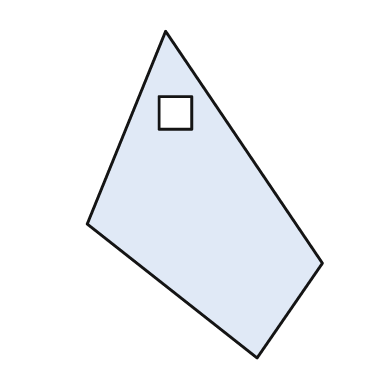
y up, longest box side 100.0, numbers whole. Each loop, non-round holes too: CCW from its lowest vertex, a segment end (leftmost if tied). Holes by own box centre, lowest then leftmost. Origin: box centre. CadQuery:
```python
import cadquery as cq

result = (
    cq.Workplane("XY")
    .moveTo(16.0, -50.0)
    .lineTo(36.0, -21.0)
    .lineTo(-12.0, 50.0)
    .lineTo(-36.0, -9.0)
    .close()
    .moveTo(-14.0, 20.0)
    .lineTo(-4.0, 20.0)
    .lineTo(-4.0, 30.0)
    .lineTo(-14.0, 30.0)
    .close()
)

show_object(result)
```